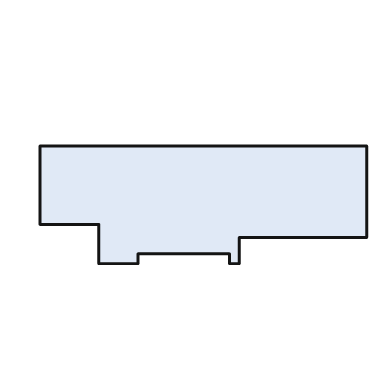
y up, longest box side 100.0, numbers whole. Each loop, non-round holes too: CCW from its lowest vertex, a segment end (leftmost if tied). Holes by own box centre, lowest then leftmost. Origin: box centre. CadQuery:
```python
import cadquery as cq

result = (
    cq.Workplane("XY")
    .moveTo(-32.0, -18.0)
    .lineTo(-20.0, -18.0)
    .lineTo(-20.0, -15.0)
    .lineTo(8.0, -15.0)
    .lineTo(8.0, -18.0)
    .lineTo(11.0, -18.0)
    .lineTo(11.0, -10.0)
    .lineTo(50.0, -10.0)
    .lineTo(50.0, 18.0)
    .lineTo(-50.0, 18.0)
    .lineTo(-50.0, -6.0)
    .lineTo(-32.0, -6.0)
    .close()
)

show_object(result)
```